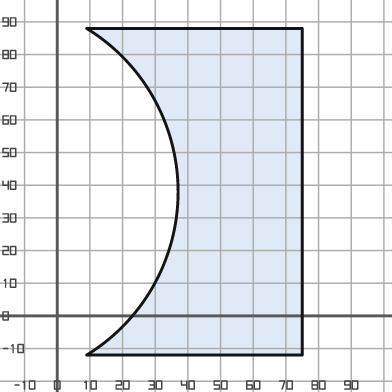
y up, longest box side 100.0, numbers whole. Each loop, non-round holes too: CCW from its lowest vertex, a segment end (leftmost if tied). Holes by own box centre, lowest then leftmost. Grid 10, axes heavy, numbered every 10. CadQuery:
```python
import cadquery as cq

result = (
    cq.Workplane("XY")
    .moveTo(9.0, -12.0)
    .lineTo(75.0, -12.0)
    .lineTo(75.0, 88.0)
    .lineTo(9.0, 88.0)
    .threePointArc((37.0, 38.0), (9.0, -12.0))
    .close()
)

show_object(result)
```